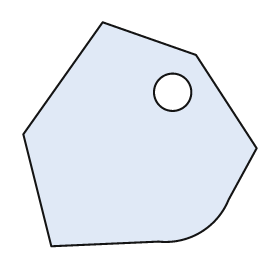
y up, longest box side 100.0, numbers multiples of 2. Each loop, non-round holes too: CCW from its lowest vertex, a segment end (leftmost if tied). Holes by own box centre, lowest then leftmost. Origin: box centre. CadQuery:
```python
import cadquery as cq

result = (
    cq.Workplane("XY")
    .moveTo(-38.0, -48.0)
    .lineTo(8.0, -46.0)
    .threePointArc((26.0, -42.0), (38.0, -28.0))
    .lineTo(50.0, -6.0)
    .lineTo(24.0, 34.0)
    .lineTo(-16.0, 48.0)
    .lineTo(-50.0, 0.0)
    .close()
    .moveTo(14.0, 18.0)
    .circle(8.0)
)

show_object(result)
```